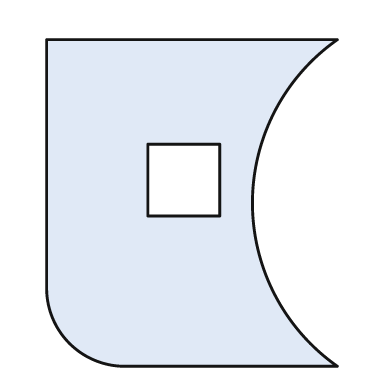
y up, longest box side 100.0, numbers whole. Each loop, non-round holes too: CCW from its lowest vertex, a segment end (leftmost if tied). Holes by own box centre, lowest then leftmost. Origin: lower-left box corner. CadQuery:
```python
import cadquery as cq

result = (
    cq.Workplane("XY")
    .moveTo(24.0, 0.0)
    .lineTo(89.0, 0.0)
    .threePointArc((63.0, 50.0), (89.0, 100.0))
    .lineTo(0.0, 100.0)
    .lineTo(0.0, 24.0)
    .threePointArc((7.0, 7.0), (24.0, 0.0))
    .close()
    .moveTo(31.0, 46.0)
    .lineTo(53.0, 46.0)
    .lineTo(53.0, 68.0)
    .lineTo(31.0, 68.0)
    .close()
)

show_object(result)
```